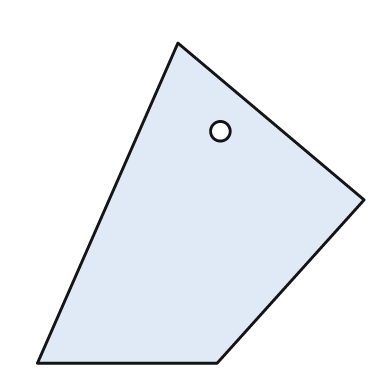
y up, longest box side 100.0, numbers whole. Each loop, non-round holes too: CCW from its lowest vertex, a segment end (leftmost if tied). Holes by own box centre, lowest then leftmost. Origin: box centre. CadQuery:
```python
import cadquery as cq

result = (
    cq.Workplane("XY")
    .moveTo(-50.0, -49.0)
    .lineTo(5.0, -49.0)
    .lineTo(50.0, 1.0)
    .lineTo(-7.0, 49.0)
    .close()
    .moveTo(6.0, 22.0)
    .circle(3.0)
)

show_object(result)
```